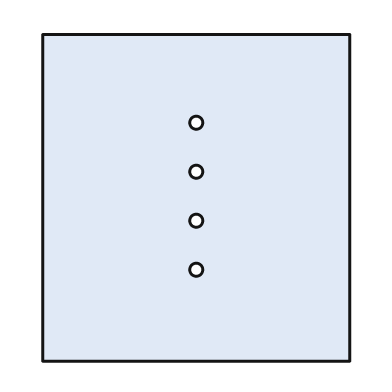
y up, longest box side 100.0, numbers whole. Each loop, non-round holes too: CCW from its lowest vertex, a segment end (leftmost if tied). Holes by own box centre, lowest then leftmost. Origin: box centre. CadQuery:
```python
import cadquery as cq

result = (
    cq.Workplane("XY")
    .moveTo(-47.0, -50.0)
    .lineTo(47.0, -50.0)
    .lineTo(47.0, 50.0)
    .lineTo(-47.0, 50.0)
    .close()
    .moveTo(0.0, -22.0)
    .circle(2.0)
    .moveTo(0.0, -7.0)
    .circle(2.0)
    .moveTo(0.0, 8.0)
    .circle(2.0)
    .moveTo(0.0, 23.0)
    .circle(2.0)
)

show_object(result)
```